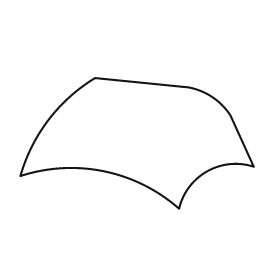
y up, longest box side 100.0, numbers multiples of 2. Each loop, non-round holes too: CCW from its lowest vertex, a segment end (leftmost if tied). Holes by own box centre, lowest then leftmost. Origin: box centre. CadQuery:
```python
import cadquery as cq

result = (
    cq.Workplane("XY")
    .moveTo(18.0, -28.0)
    .threePointArc((30.0, -12.0), (50.0, -10.0))
    .lineTo(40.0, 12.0)
    .threePointArc((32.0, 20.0), (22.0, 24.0))
    .lineTo(-18.0, 28.0)
    .threePointArc((-38.0, 10.0), (-50.0, -14.0))
    .threePointArc((-14.0, -12.0), (18.0, -28.0))
    .close()
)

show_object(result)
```